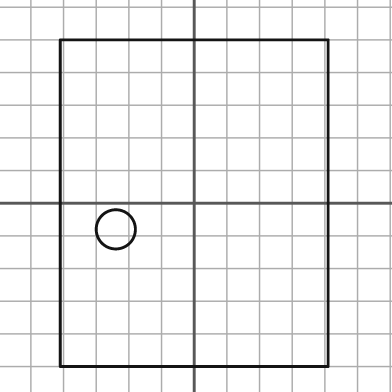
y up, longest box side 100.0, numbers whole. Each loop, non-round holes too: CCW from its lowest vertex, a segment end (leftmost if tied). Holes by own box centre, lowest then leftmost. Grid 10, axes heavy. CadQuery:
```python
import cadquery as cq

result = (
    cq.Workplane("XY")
    .moveTo(-41.0, -50.0)
    .lineTo(41.0, -50.0)
    .lineTo(41.0, 50.0)
    .lineTo(-41.0, 50.0)
    .close()
    .moveTo(-24.0, -8.0)
    .circle(6.0)
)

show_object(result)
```